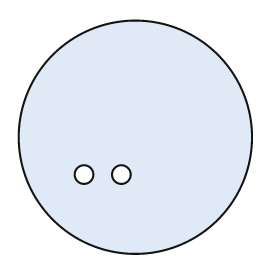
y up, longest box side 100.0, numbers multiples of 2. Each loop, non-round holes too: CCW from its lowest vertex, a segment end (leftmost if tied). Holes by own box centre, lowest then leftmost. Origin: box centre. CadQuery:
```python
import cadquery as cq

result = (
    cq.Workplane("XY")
    .moveTo(0.0, 0.0)
    .circle(50.0)
    .moveTo(-22.0, -16.0)
    .circle(4.0)
    .moveTo(-6.0, -16.0)
    .circle(4.0)
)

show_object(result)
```